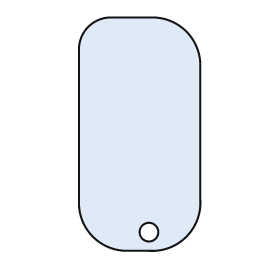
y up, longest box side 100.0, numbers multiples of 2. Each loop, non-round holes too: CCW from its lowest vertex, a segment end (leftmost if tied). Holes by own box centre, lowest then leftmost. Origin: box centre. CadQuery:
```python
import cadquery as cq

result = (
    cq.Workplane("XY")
    .moveTo(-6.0, -50.0)
    .lineTo(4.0, -50.0)
    .threePointArc((20.0, -44.0), (26.0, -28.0))
    .lineTo(26.0, 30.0)
    .threePointArc((20.0, 44.0), (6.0, 50.0))
    .lineTo(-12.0, 50.0)
    .threePointArc((-22.0, 46.0), (-26.0, 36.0))
    .lineTo(-26.0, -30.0)
    .threePointArc((-20.0, -44.0), (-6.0, -50.0))
    .close()
    .moveTo(4.0, -42.0)
    .circle(4.0)
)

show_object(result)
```